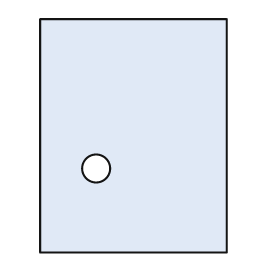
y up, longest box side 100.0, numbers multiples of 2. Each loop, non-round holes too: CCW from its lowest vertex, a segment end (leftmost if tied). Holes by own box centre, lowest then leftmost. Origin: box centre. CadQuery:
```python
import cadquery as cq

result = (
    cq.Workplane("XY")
    .moveTo(-40.0, -50.0)
    .lineTo(40.0, -50.0)
    .lineTo(40.0, 50.0)
    .lineTo(-40.0, 50.0)
    .close()
    .moveTo(-16.0, -14.0)
    .circle(6.0)
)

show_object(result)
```